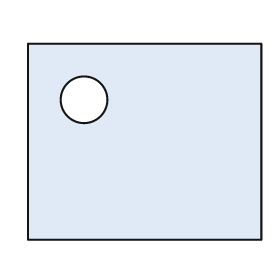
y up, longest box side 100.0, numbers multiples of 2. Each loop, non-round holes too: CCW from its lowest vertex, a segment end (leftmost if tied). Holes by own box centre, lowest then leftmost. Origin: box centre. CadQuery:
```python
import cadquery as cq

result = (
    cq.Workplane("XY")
    .moveTo(-50.0, -42.0)
    .lineTo(50.0, -42.0)
    .lineTo(50.0, 42.0)
    .lineTo(-50.0, 42.0)
    .close()
    .moveTo(-26.0, 18.0)
    .circle(10.0)
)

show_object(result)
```